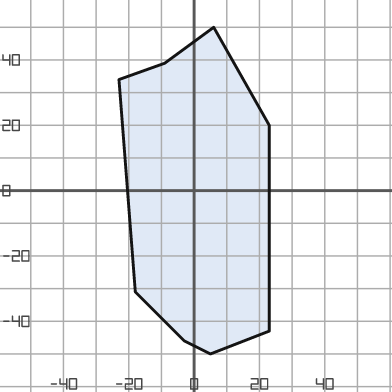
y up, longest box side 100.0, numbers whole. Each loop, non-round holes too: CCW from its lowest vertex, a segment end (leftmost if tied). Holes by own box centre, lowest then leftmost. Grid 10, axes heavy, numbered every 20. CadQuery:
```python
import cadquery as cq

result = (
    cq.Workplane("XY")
    .moveTo(5.0, -50.0)
    .lineTo(23.0, -43.0)
    .lineTo(23.0, 20.0)
    .lineTo(6.0, 50.0)
    .lineTo(-9.0, 39.0)
    .lineTo(-23.0, 34.0)
    .lineTo(-18.0, -31.0)
    .lineTo(-3.0, -46.0)
    .close()
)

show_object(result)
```